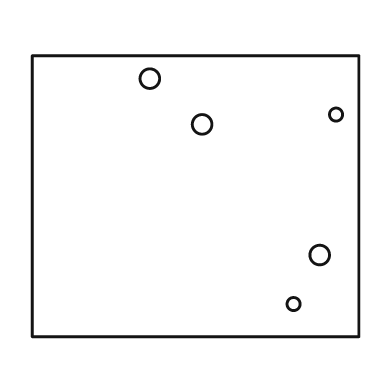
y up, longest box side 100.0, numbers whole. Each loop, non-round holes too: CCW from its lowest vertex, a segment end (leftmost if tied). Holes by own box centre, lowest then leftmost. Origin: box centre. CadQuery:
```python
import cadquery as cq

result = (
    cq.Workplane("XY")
    .moveTo(-50.0, -43.0)
    .lineTo(50.0, -43.0)
    .lineTo(50.0, 43.0)
    .lineTo(-50.0, 43.0)
    .close()
    .moveTo(30.0, -33.0)
    .circle(2.0)
    .moveTo(38.0, -18.0)
    .circle(3.0)
    .moveTo(2.0, 22.0)
    .circle(3.0)
    .moveTo(43.0, 25.0)
    .circle(2.0)
    .moveTo(-14.0, 36.0)
    .circle(3.0)
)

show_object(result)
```